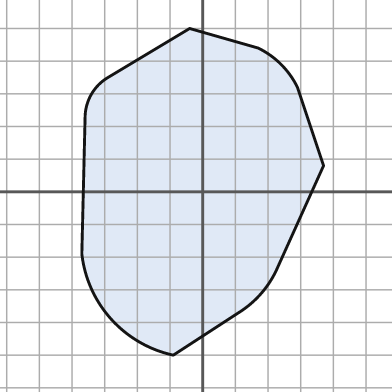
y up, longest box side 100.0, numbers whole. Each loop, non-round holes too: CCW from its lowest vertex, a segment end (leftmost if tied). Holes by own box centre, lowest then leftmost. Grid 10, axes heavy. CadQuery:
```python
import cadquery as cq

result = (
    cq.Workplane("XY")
    .moveTo(-9.0, -50.0)
    .lineTo(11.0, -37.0)
    .threePointArc((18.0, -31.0), (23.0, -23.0))
    .lineTo(37.0, 8.0)
    .lineTo(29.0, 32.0)
    .threePointArc((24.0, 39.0), (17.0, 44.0))
    .lineTo(-4.0, 50.0)
    .lineTo(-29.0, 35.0)
    .threePointArc((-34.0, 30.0), (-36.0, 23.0))
    .lineTo(-37.0, -19.0)
    .threePointArc((-28.0, -39.0), (-9.0, -50.0))
    .close()
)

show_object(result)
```